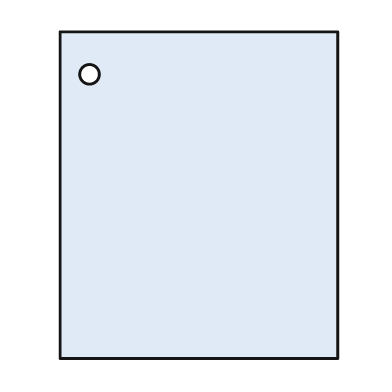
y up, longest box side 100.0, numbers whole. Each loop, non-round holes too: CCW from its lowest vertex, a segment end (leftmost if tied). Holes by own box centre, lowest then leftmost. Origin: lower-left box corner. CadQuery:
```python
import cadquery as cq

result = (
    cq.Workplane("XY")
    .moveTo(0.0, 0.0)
    .lineTo(85.0, 0.0)
    .lineTo(85.0, 100.0)
    .lineTo(0.0, 100.0)
    .close()
    .moveTo(9.0, 87.0)
    .circle(3.0)
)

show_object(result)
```